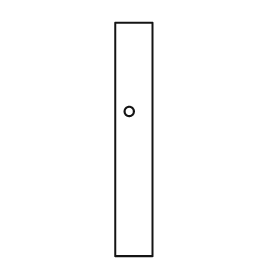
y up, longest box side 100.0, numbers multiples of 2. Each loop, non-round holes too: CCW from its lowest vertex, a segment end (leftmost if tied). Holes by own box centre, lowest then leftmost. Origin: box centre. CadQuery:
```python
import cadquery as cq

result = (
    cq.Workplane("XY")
    .moveTo(-8.0, -50.0)
    .lineTo(8.0, -50.0)
    .lineTo(8.0, 50.0)
    .lineTo(-8.0, 50.0)
    .close()
    .moveTo(-2.0, 12.0)
    .circle(2.0)
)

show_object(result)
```